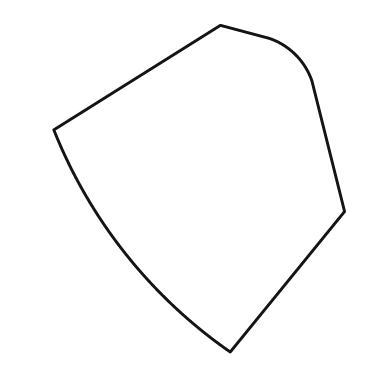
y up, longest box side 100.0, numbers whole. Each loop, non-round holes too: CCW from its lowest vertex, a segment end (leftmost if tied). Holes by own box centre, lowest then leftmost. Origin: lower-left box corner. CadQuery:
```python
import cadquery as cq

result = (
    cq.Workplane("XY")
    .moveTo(54.0, 0.0)
    .lineTo(89.0, 43.0)
    .lineTo(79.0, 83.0)
    .threePointArc((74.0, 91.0), (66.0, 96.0))
    .lineTo(51.0, 100.0)
    .lineTo(0.0, 68.0)
    .threePointArc((22.0, 30.0), (54.0, 0.0))
    .close()
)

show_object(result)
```